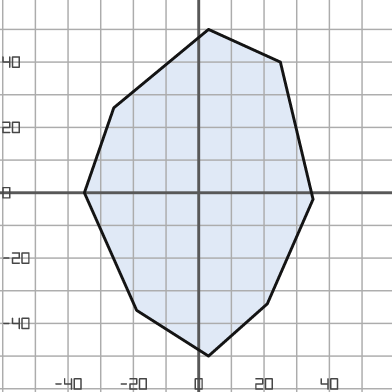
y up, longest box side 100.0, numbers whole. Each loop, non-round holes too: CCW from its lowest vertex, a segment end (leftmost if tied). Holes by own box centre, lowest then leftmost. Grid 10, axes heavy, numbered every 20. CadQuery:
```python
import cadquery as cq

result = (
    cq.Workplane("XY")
    .moveTo(3.0, -50.0)
    .lineTo(21.0, -34.0)
    .lineTo(35.0, -2.0)
    .lineTo(25.0, 40.0)
    .lineTo(3.0, 50.0)
    .lineTo(-26.0, 26.0)
    .lineTo(-35.0, 0.0)
    .lineTo(-19.0, -36.0)
    .close()
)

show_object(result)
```